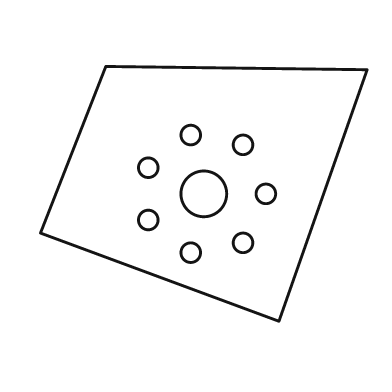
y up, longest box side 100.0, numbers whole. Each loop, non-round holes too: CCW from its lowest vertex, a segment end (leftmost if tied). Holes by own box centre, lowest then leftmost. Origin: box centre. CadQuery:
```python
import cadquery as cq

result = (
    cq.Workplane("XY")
    .moveTo(23.0, -39.0)
    .lineTo(50.0, 38.0)
    .lineTo(-30.0, 39.0)
    .lineTo(-50.0, -12.0)
    .close()
    .moveTo(-4.0, -18.0)
    .circle(3.0)
    .moveTo(12.0, -15.0)
    .circle(3.0)
    .moveTo(-17.0, -8.0)
    .circle(3.0)
    .moveTo(0.0, 0.0)
    .circle(7.0)
    .moveTo(19.0, 0.0)
    .circle(3.0)
    .moveTo(-17.0, 8.0)
    .circle(3.0)
    .moveTo(12.0, 15.0)
    .circle(3.0)
    .moveTo(-4.0, 18.0)
    .circle(3.0)
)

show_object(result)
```